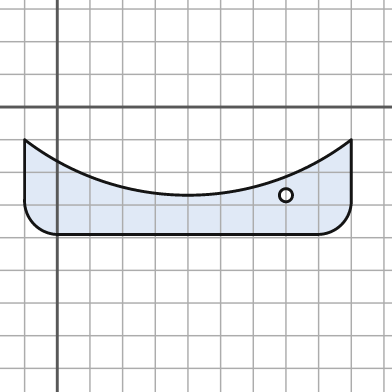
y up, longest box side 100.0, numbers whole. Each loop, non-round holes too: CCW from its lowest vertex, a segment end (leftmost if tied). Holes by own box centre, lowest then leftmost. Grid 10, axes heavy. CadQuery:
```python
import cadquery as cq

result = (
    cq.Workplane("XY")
    .moveTo(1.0, -39.0)
    .lineTo(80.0, -39.0)
    .threePointArc((87.0, -36.0), (90.0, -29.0))
    .lineTo(90.0, -10.0)
    .threePointArc((40.0, -27.0), (-10.0, -10.0))
    .lineTo(-10.0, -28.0)
    .threePointArc((-7.0, -36.0), (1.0, -39.0))
    .close()
    .moveTo(70.0, -27.0)
    .circle(2.0)
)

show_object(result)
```